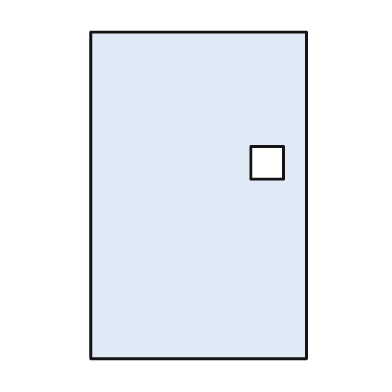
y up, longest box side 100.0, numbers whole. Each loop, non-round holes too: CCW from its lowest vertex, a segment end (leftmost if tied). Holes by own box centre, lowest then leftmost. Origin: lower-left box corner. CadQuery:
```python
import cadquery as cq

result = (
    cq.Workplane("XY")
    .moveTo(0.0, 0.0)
    .lineTo(66.0, 0.0)
    .lineTo(66.0, 100.0)
    .lineTo(0.0, 100.0)
    .close()
    .moveTo(49.0, 55.0)
    .lineTo(59.0, 55.0)
    .lineTo(59.0, 65.0)
    .lineTo(49.0, 65.0)
    .close()
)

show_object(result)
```